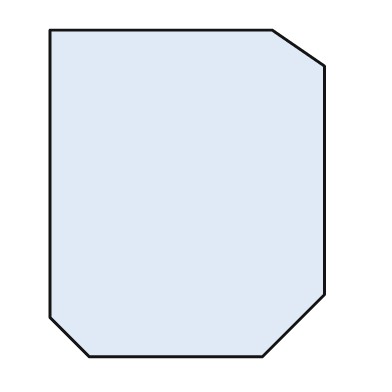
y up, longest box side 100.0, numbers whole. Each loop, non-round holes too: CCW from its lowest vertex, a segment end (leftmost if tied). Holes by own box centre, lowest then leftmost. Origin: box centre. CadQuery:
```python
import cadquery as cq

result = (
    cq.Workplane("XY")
    .moveTo(-30.0, -50.0)
    .lineTo(23.0, -50.0)
    .lineTo(42.0, -31.0)
    .lineTo(42.0, 39.0)
    .lineTo(26.0, 50.0)
    .lineTo(-42.0, 50.0)
    .lineTo(-42.0, -38.0)
    .close()
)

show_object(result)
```